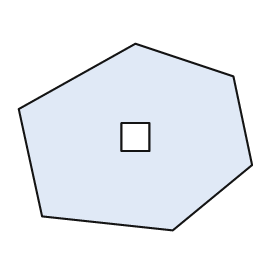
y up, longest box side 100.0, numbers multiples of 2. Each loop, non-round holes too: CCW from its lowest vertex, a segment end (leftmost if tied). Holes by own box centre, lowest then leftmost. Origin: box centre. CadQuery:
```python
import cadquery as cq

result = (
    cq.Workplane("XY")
    .moveTo(16.0, -40.0)
    .lineTo(50.0, -12.0)
    .lineTo(42.0, 26.0)
    .lineTo(0.0, 40.0)
    .lineTo(-50.0, 12.0)
    .lineTo(-40.0, -34.0)
    .close()
    .moveTo(-6.0, -6.0)
    .lineTo(6.0, -6.0)
    .lineTo(6.0, 6.0)
    .lineTo(-6.0, 6.0)
    .close()
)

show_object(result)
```